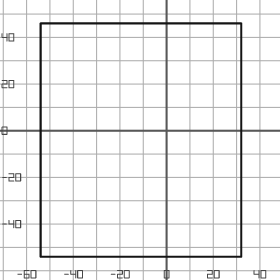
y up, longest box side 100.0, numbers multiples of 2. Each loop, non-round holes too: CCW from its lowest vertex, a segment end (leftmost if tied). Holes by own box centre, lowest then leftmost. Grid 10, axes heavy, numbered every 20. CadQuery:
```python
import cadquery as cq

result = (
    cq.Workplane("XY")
    .moveTo(-54.0, -54.0)
    .lineTo(32.0, -54.0)
    .lineTo(32.0, 46.0)
    .lineTo(-54.0, 46.0)
    .close()
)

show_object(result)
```